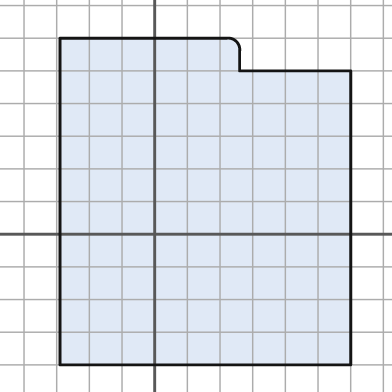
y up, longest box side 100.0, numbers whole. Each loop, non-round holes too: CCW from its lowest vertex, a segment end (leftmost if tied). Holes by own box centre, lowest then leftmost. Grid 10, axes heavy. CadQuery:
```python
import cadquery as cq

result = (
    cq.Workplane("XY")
    .moveTo(-29.0, -40.0)
    .lineTo(60.0, -40.0)
    .lineTo(60.0, 50.0)
    .lineTo(26.0, 50.0)
    .lineTo(26.0, 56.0)
    .threePointArc((25.0, 59.0), (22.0, 60.0))
    .lineTo(-29.0, 60.0)
    .close()
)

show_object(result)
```